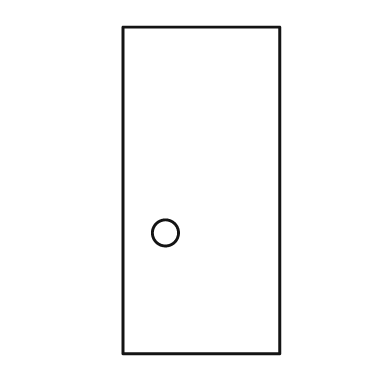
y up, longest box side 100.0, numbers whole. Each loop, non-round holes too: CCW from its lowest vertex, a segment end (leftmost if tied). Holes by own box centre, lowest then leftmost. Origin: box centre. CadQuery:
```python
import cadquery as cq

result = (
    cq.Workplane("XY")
    .moveTo(-24.0, -50.0)
    .lineTo(24.0, -50.0)
    .lineTo(24.0, 50.0)
    .lineTo(-24.0, 50.0)
    .close()
    .moveTo(-11.0, -13.0)
    .circle(4.0)
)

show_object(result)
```